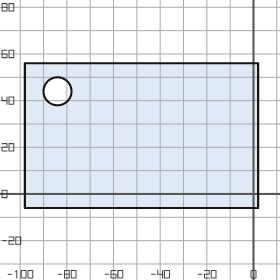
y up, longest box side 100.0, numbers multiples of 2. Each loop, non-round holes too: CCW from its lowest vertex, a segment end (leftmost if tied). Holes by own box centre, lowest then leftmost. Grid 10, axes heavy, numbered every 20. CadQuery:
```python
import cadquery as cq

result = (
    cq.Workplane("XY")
    .moveTo(-98.0, -6.0)
    .lineTo(2.0, -6.0)
    .lineTo(2.0, 56.0)
    .lineTo(-98.0, 56.0)
    .close()
    .moveTo(-84.0, 44.0)
    .circle(6.0)
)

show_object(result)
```